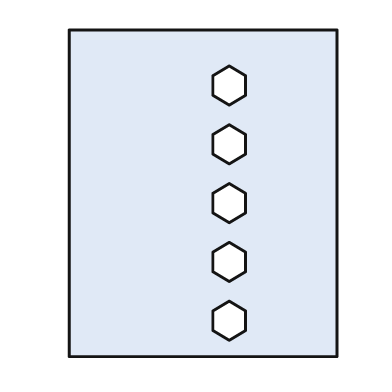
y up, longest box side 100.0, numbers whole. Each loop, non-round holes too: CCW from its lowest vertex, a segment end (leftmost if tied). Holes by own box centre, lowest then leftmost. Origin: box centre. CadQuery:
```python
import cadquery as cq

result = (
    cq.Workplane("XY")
    .moveTo(-41.0, -50.0)
    .lineTo(41.0, -50.0)
    .lineTo(41.0, 50.0)
    .lineTo(-41.0, 50.0)
    .close()
    .moveTo(8.0, -45.0)
    .lineTo(13.0, -42.0)
    .lineTo(13.0, -36.0)
    .lineTo(8.0, -33.0)
    .lineTo(3.0, -36.0)
    .lineTo(3.0, -42.0)
    .close()
    .moveTo(8.0, -27.0)
    .lineTo(13.0, -24.0)
    .lineTo(13.0, -18.0)
    .lineTo(8.0, -15.0)
    .lineTo(3.0, -18.0)
    .lineTo(3.0, -24.0)
    .close()
    .moveTo(8.0, -9.0)
    .lineTo(13.0, -6.0)
    .lineTo(13.0, 0.0)
    .lineTo(8.0, 3.0)
    .lineTo(3.0, 0.0)
    .lineTo(3.0, -6.0)
    .close()
    .moveTo(8.0, 9.0)
    .lineTo(13.0, 12.0)
    .lineTo(13.0, 18.0)
    .lineTo(8.0, 21.0)
    .lineTo(3.0, 18.0)
    .lineTo(3.0, 12.0)
    .close()
    .moveTo(8.0, 27.0)
    .lineTo(13.0, 30.0)
    .lineTo(13.0, 36.0)
    .lineTo(8.0, 39.0)
    .lineTo(3.0, 36.0)
    .lineTo(3.0, 30.0)
    .close()
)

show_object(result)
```